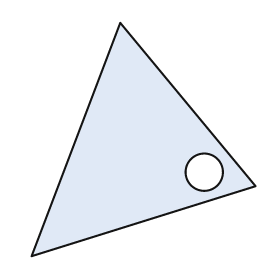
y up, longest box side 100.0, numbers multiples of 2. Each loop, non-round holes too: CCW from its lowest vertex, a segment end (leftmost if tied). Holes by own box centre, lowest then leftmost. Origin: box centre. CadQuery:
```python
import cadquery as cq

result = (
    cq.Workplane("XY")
    .moveTo(-48.0, -50.0)
    .lineTo(48.0, -20.0)
    .lineTo(-10.0, 50.0)
    .close()
    .moveTo(26.0, -14.0)
    .circle(8.0)
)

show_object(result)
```